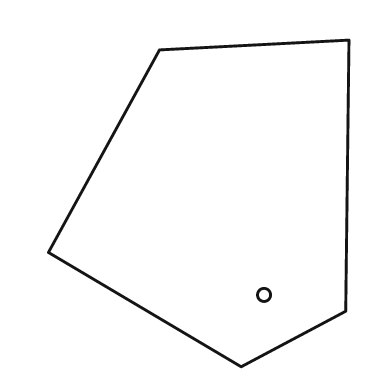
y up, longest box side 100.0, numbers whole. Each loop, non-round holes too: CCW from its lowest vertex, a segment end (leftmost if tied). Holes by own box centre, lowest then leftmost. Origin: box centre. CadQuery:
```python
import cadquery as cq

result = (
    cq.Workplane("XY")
    .moveTo(13.0, -50.0)
    .lineTo(45.0, -33.0)
    .lineTo(46.0, 50.0)
    .lineTo(-12.0, 47.0)
    .lineTo(-46.0, -15.0)
    .close()
    .moveTo(20.0, -28.0)
    .circle(2.0)
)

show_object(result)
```